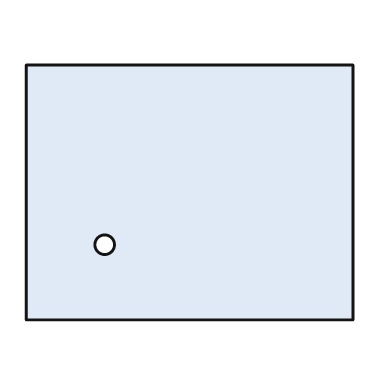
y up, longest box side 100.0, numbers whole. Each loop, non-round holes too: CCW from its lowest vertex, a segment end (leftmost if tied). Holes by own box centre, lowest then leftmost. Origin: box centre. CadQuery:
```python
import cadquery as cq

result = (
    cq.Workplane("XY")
    .moveTo(-50.0, -39.0)
    .lineTo(50.0, -39.0)
    .lineTo(50.0, 39.0)
    .lineTo(-50.0, 39.0)
    .close()
    .moveTo(-26.0, -16.0)
    .circle(3.0)
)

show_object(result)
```